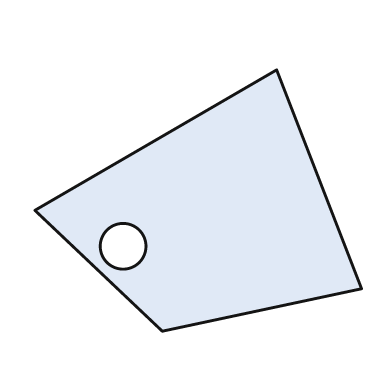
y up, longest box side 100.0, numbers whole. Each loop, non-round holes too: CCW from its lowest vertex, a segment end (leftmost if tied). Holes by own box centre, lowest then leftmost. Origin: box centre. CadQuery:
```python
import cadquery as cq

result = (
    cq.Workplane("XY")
    .moveTo(-11.0, -40.0)
    .lineTo(50.0, -27.0)
    .lineTo(24.0, 40.0)
    .lineTo(-50.0, -3.0)
    .close()
    .moveTo(-23.0, -14.0)
    .circle(7.0)
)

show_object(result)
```